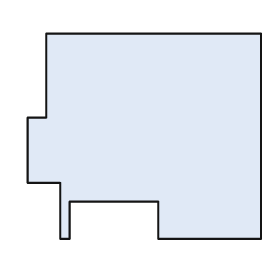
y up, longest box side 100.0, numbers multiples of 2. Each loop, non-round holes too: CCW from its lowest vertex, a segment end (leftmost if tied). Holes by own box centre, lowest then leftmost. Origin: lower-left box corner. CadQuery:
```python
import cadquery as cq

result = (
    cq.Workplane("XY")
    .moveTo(14.0, 0.0)
    .lineTo(18.0, 0.0)
    .lineTo(18.0, 16.0)
    .lineTo(56.0, 16.0)
    .lineTo(56.0, 0.0)
    .lineTo(100.0, 0.0)
    .lineTo(100.0, 88.0)
    .lineTo(8.0, 88.0)
    .lineTo(8.0, 52.0)
    .lineTo(0.0, 52.0)
    .lineTo(0.0, 24.0)
    .lineTo(14.0, 24.0)
    .close()
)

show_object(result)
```